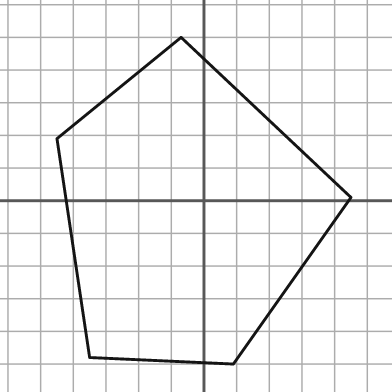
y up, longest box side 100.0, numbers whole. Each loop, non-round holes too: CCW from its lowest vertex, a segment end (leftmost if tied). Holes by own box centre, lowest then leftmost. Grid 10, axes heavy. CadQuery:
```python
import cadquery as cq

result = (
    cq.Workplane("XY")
    .moveTo(9.0, -50.0)
    .lineTo(45.0, 1.0)
    .lineTo(-7.0, 50.0)
    .lineTo(-45.0, 19.0)
    .lineTo(-35.0, -48.0)
    .close()
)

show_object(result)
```